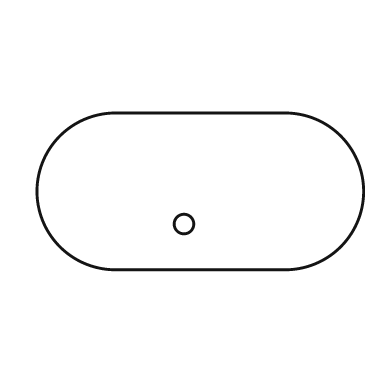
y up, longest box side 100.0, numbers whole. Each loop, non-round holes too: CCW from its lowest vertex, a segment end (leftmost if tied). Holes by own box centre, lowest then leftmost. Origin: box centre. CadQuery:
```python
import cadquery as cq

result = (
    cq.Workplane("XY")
    .moveTo(-26.0, -24.0)
    .lineTo(26.0, -24.0)
    .threePointArc((50.0, 0.0), (26.0, 24.0))
    .lineTo(-26.0, 24.0)
    .threePointArc((-50.0, 0.0), (-26.0, -24.0))
    .close()
    .moveTo(-5.0, -10.0)
    .circle(3.0)
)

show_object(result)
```